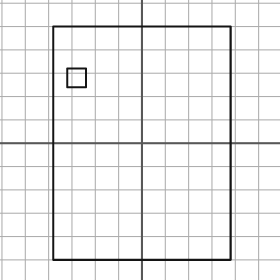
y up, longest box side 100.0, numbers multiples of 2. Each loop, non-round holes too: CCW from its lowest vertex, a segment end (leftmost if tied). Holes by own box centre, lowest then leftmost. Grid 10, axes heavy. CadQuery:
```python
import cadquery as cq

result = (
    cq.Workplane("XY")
    .moveTo(-38.0, -50.0)
    .lineTo(38.0, -50.0)
    .lineTo(38.0, 50.0)
    .lineTo(-38.0, 50.0)
    .close()
    .moveTo(-32.0, 24.0)
    .lineTo(-24.0, 24.0)
    .lineTo(-24.0, 32.0)
    .lineTo(-32.0, 32.0)
    .close()
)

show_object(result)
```